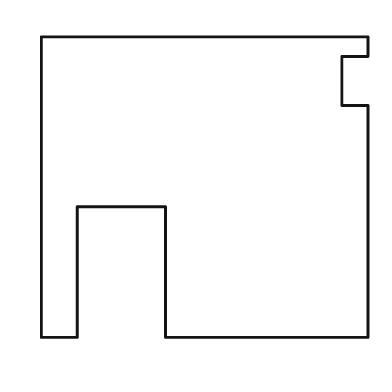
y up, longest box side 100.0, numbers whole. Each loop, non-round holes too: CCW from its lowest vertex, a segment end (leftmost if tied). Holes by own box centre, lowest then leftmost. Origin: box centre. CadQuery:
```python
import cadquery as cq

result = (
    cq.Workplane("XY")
    .moveTo(-50.0, -46.0)
    .lineTo(-39.0, -46.0)
    .lineTo(-39.0, -6.0)
    .lineTo(-12.0, -6.0)
    .lineTo(-12.0, -46.0)
    .lineTo(50.0, -46.0)
    .lineTo(50.0, 25.0)
    .lineTo(42.0, 25.0)
    .lineTo(42.0, 40.0)
    .lineTo(50.0, 40.0)
    .lineTo(50.0, 46.0)
    .lineTo(-50.0, 46.0)
    .close()
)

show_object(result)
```